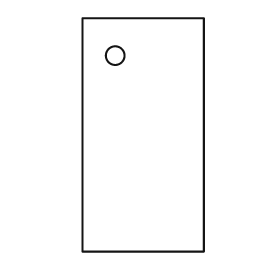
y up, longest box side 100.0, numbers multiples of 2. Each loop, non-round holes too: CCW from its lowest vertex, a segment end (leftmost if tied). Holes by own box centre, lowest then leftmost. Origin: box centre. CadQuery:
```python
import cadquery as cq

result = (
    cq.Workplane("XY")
    .moveTo(-26.0, -50.0)
    .lineTo(26.0, -50.0)
    .lineTo(26.0, 50.0)
    .lineTo(-26.0, 50.0)
    .close()
    .moveTo(-12.0, 34.0)
    .circle(4.0)
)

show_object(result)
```